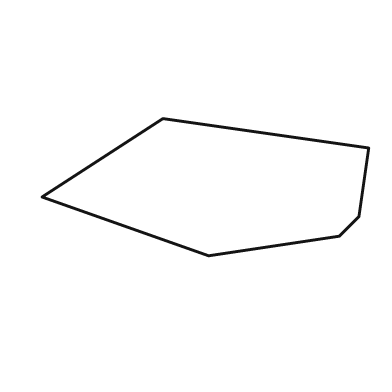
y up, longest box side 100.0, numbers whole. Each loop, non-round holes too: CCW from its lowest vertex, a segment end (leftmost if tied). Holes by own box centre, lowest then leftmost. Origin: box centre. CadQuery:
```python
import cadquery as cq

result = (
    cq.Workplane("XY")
    .moveTo(1.0, -21.0)
    .lineTo(41.0, -15.0)
    .lineTo(47.0, -9.0)
    .lineTo(50.0, 12.0)
    .lineTo(-13.0, 21.0)
    .lineTo(-50.0, -3.0)
    .close()
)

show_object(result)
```